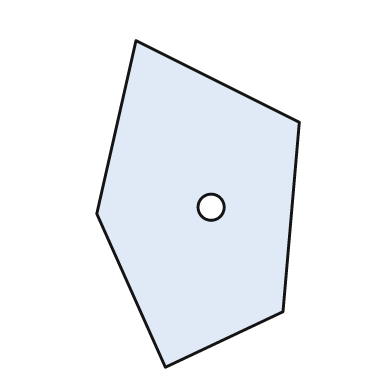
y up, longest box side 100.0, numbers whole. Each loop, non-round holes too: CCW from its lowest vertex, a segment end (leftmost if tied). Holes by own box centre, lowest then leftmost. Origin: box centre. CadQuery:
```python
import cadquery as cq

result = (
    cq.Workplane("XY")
    .moveTo(-10.0, -50.0)
    .lineTo(26.0, -33.0)
    .lineTo(31.0, 25.0)
    .lineTo(-19.0, 50.0)
    .lineTo(-31.0, -3.0)
    .close()
    .moveTo(4.0, -1.0)
    .circle(4.0)
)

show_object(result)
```